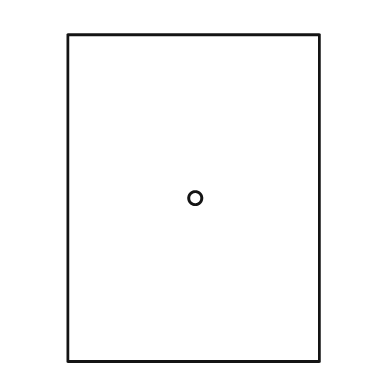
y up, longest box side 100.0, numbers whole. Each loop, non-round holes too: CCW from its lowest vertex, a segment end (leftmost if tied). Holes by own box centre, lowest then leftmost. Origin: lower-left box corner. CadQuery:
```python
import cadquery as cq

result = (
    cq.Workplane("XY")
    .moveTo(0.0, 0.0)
    .lineTo(77.0, 0.0)
    .lineTo(77.0, 100.0)
    .lineTo(0.0, 100.0)
    .close()
    .moveTo(39.0, 50.0)
    .circle(2.0)
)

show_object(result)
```